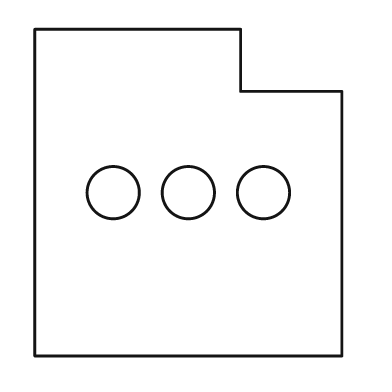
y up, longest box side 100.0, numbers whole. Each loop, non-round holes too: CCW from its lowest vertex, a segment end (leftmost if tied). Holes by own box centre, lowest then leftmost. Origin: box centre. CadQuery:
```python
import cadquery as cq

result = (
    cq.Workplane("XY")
    .moveTo(-47.0, -50.0)
    .lineTo(47.0, -50.0)
    .lineTo(47.0, 31.0)
    .lineTo(16.0, 31.0)
    .lineTo(16.0, 50.0)
    .lineTo(-47.0, 50.0)
    .close()
    .moveTo(-23.0, 0.0)
    .circle(8.0)
    .moveTo(0.0, 0.0)
    .circle(8.0)
    .moveTo(23.0, 0.0)
    .circle(8.0)
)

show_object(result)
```